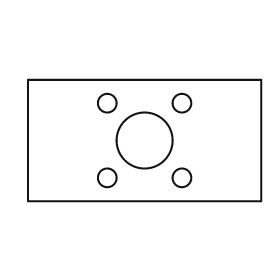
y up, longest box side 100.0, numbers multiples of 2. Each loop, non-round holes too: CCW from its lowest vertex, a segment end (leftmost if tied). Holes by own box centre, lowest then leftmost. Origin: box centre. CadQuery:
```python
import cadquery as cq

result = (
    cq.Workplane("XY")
    .moveTo(-50.0, -26.0)
    .lineTo(50.0, -26.0)
    .lineTo(50.0, 26.0)
    .lineTo(-50.0, 26.0)
    .close()
    .moveTo(-16.0, -16.0)
    .circle(4.0)
    .moveTo(16.0, -16.0)
    .circle(4.0)
    .moveTo(0.0, 0.0)
    .circle(12.0)
    .moveTo(-16.0, 16.0)
    .circle(4.0)
    .moveTo(16.0, 16.0)
    .circle(4.0)
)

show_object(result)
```